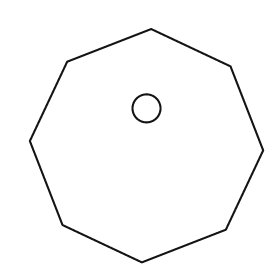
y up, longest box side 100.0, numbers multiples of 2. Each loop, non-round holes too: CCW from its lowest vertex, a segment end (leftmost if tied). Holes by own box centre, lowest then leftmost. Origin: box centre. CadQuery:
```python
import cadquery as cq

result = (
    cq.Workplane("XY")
    .moveTo(-2.0, -50.0)
    .lineTo(34.0, -36.0)
    .lineTo(50.0, -2.0)
    .lineTo(36.0, 34.0)
    .lineTo(2.0, 50.0)
    .lineTo(-34.0, 36.0)
    .lineTo(-50.0, 2.0)
    .lineTo(-36.0, -34.0)
    .close()
    .moveTo(0.0, 16.0)
    .circle(6.0)
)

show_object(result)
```